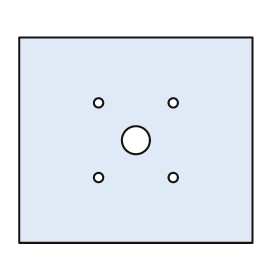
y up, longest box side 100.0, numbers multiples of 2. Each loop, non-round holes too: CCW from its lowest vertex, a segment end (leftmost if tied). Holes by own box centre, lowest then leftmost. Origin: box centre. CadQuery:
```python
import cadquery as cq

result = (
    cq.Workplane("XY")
    .moveTo(-50.0, -44.0)
    .lineTo(50.0, -44.0)
    .lineTo(50.0, 44.0)
    .lineTo(-50.0, 44.0)
    .close()
    .moveTo(-16.0, -16.0)
    .circle(2.0)
    .moveTo(16.0, -16.0)
    .circle(2.0)
    .moveTo(0.0, 0.0)
    .circle(6.0)
    .moveTo(-16.0, 16.0)
    .circle(2.0)
    .moveTo(16.0, 16.0)
    .circle(2.0)
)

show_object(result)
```